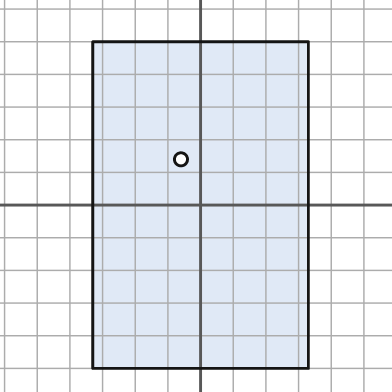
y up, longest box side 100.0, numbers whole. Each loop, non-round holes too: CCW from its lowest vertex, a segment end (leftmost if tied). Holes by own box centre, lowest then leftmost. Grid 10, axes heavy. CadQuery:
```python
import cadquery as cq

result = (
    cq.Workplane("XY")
    .moveTo(-33.0, -50.0)
    .lineTo(33.0, -50.0)
    .lineTo(33.0, 50.0)
    .lineTo(-33.0, 50.0)
    .close()
    .moveTo(-6.0, 14.0)
    .circle(2.0)
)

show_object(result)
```